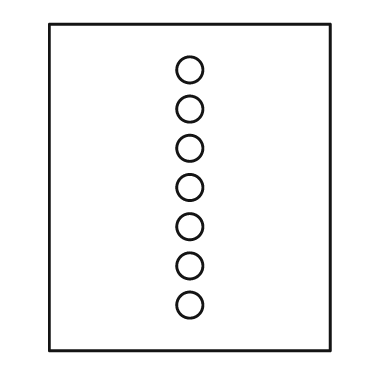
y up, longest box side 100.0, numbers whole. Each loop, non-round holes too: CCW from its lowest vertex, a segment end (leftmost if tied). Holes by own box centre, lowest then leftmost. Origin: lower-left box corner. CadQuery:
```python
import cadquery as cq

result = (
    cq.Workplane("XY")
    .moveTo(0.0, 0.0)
    .lineTo(86.0, 0.0)
    .lineTo(86.0, 100.0)
    .lineTo(0.0, 100.0)
    .close()
    .moveTo(43.0, 14.0)
    .circle(4.0)
    .moveTo(43.0, 26.0)
    .circle(4.0)
    .moveTo(43.0, 38.0)
    .circle(4.0)
    .moveTo(43.0, 50.0)
    .circle(4.0)
    .moveTo(43.0, 62.0)
    .circle(4.0)
    .moveTo(43.0, 74.0)
    .circle(4.0)
    .moveTo(43.0, 86.0)
    .circle(4.0)
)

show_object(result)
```